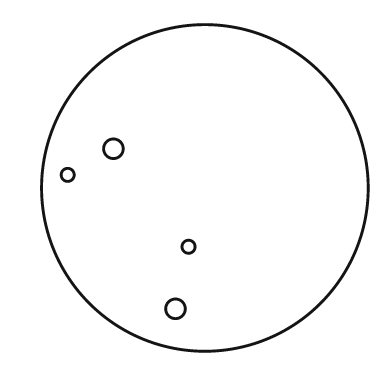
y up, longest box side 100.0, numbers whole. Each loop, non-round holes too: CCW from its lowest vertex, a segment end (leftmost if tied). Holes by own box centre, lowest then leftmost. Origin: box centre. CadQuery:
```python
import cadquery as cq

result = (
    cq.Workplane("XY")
    .moveTo(0.0, 0.0)
    .circle(50.0)
    .moveTo(-9.0, -37.0)
    .circle(3.0)
    .moveTo(-5.0, -18.0)
    .circle(2.0)
    .moveTo(-42.0, 4.0)
    .circle(2.0)
    .moveTo(-28.0, 12.0)
    .circle(3.0)
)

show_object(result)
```